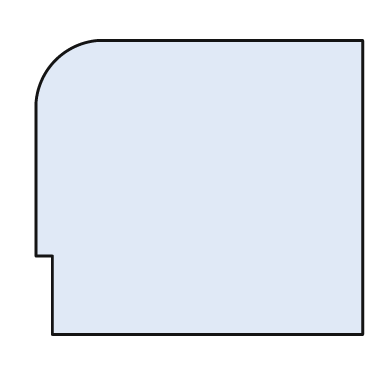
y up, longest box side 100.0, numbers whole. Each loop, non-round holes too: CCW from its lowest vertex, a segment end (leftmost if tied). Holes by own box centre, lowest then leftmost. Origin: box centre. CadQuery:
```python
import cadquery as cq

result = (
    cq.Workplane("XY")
    .moveTo(-45.0, -45.0)
    .lineTo(50.0, -45.0)
    .lineTo(50.0, 45.0)
    .lineTo(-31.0, 45.0)
    .threePointArc((-44.0, 39.0), (-50.0, 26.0))
    .lineTo(-50.0, -21.0)
    .lineTo(-45.0, -21.0)
    .close()
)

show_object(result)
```